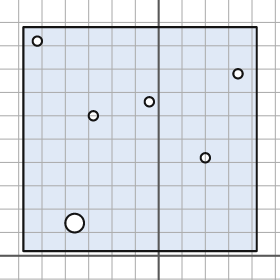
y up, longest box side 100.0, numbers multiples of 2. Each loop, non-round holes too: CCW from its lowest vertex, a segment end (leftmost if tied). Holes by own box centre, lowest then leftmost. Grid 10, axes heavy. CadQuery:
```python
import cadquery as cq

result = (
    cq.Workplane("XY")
    .moveTo(-58.0, 2.0)
    .lineTo(42.0, 2.0)
    .lineTo(42.0, 98.0)
    .lineTo(-58.0, 98.0)
    .close()
    .moveTo(-36.0, 14.0)
    .circle(4.0)
    .moveTo(20.0, 42.0)
    .circle(2.0)
    .moveTo(-28.0, 60.0)
    .circle(2.0)
    .moveTo(-4.0, 66.0)
    .circle(2.0)
    .moveTo(34.0, 78.0)
    .circle(2.0)
    .moveTo(-52.0, 92.0)
    .circle(2.0)
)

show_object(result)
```